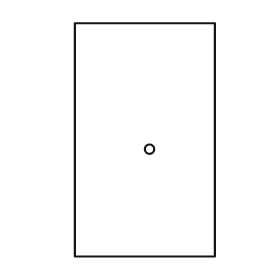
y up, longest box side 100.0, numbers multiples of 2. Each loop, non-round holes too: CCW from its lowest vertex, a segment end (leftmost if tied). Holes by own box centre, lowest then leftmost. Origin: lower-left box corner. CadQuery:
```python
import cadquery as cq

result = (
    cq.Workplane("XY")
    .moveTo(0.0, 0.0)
    .lineTo(60.0, 0.0)
    .lineTo(60.0, 100.0)
    .lineTo(0.0, 100.0)
    .close()
    .moveTo(32.0, 46.0)
    .circle(2.0)
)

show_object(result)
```